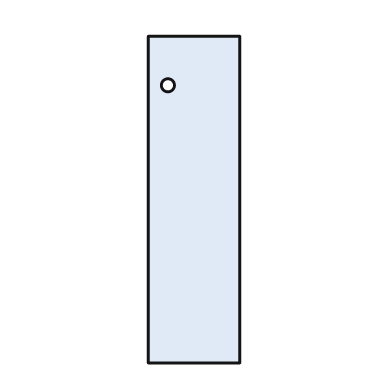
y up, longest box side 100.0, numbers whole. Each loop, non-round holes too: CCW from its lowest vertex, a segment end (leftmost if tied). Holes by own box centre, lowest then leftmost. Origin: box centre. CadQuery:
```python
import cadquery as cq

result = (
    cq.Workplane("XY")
    .moveTo(-14.0, -50.0)
    .lineTo(14.0, -50.0)
    .lineTo(14.0, 50.0)
    .lineTo(-14.0, 50.0)
    .close()
    .moveTo(-8.0, 35.0)
    .circle(2.0)
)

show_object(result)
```